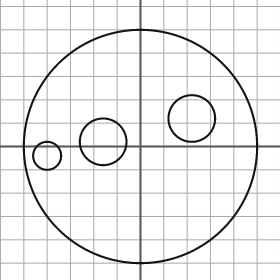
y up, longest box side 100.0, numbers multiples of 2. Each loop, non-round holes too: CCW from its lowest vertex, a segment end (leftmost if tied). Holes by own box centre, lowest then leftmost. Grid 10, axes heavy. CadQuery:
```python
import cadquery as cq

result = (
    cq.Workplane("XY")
    .moveTo(0.0, 0.0)
    .circle(50.0)
    .moveTo(-40.0, -4.0)
    .circle(6.0)
    .moveTo(-16.0, 2.0)
    .circle(10.0)
    .moveTo(22.0, 12.0)
    .circle(10.0)
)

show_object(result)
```